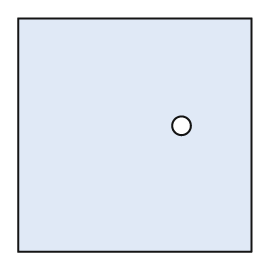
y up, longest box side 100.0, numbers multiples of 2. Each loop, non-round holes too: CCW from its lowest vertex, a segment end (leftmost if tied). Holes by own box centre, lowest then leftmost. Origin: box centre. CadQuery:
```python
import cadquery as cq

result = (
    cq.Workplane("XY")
    .moveTo(-50.0, -50.0)
    .lineTo(50.0, -50.0)
    .lineTo(50.0, 50.0)
    .lineTo(-50.0, 50.0)
    .close()
    .moveTo(20.0, 4.0)
    .circle(4.0)
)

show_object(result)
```